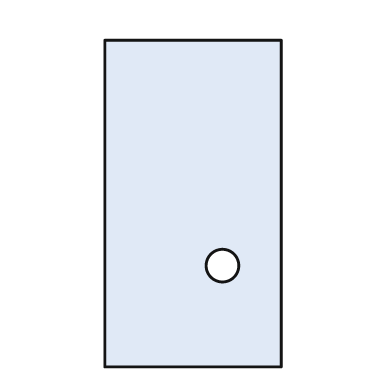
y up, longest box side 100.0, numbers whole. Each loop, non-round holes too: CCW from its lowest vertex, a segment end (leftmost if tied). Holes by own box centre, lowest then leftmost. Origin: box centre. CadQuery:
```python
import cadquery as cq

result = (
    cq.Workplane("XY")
    .moveTo(-27.0, -50.0)
    .lineTo(27.0, -50.0)
    .lineTo(27.0, 50.0)
    .lineTo(-27.0, 50.0)
    .close()
    .moveTo(9.0, -19.0)
    .circle(5.0)
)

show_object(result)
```